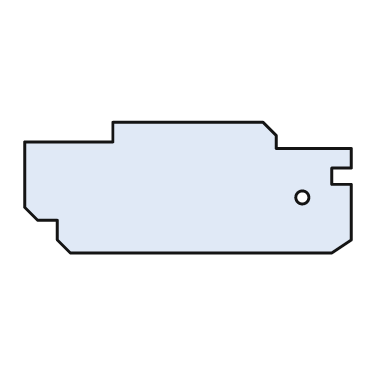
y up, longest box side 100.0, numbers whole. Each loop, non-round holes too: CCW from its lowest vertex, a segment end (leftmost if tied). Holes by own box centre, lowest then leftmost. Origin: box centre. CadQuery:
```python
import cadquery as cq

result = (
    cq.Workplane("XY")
    .moveTo(-36.0, -20.0)
    .lineTo(44.0, -20.0)
    .lineTo(50.0, -16.0)
    .lineTo(50.0, 1.0)
    .lineTo(44.0, 1.0)
    .lineTo(44.0, 6.0)
    .lineTo(50.0, 6.0)
    .lineTo(50.0, 12.0)
    .lineTo(27.0, 12.0)
    .lineTo(27.0, 16.0)
    .lineTo(23.0, 20.0)
    .lineTo(-23.0, 20.0)
    .lineTo(-23.0, 14.0)
    .lineTo(-50.0, 14.0)
    .lineTo(-50.0, -6.0)
    .lineTo(-46.0, -10.0)
    .lineTo(-40.0, -10.0)
    .lineTo(-40.0, -16.0)
    .close()
    .moveTo(35.0, -3.0)
    .circle(2.0)
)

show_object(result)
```